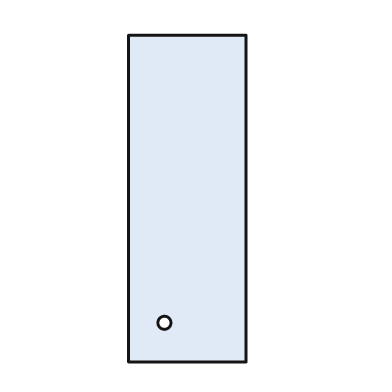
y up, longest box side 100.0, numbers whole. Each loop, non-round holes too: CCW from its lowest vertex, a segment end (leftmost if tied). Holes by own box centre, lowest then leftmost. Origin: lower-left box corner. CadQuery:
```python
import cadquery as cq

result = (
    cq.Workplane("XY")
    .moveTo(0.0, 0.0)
    .lineTo(36.0, 0.0)
    .lineTo(36.0, 100.0)
    .lineTo(0.0, 100.0)
    .close()
    .moveTo(11.0, 12.0)
    .circle(2.0)
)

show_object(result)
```